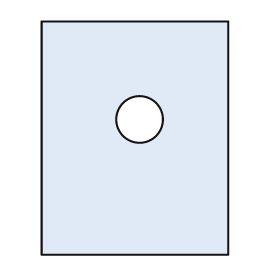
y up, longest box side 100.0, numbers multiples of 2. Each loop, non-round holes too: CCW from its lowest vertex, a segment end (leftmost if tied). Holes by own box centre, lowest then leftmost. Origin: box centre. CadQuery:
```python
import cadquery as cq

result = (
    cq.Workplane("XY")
    .moveTo(-40.0, -50.0)
    .lineTo(40.0, -50.0)
    .lineTo(40.0, 50.0)
    .lineTo(-40.0, 50.0)
    .close()
    .moveTo(2.0, 8.0)
    .circle(10.0)
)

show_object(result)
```